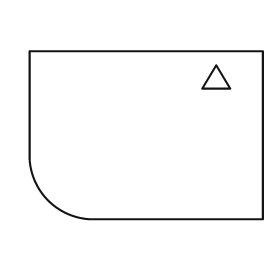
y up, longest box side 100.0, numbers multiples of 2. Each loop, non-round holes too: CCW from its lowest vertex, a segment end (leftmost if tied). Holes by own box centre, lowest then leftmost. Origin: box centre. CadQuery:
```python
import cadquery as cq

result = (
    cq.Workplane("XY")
    .moveTo(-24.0, -36.0)
    .lineTo(50.0, -36.0)
    .lineTo(50.0, 36.0)
    .lineTo(-50.0, 36.0)
    .lineTo(-50.0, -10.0)
    .threePointArc((-42.0, -28.0), (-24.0, -36.0))
    .close()
    .moveTo(24.0, 20.0)
    .lineTo(36.0, 20.0)
    .lineTo(30.0, 30.0)
    .close()
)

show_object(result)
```